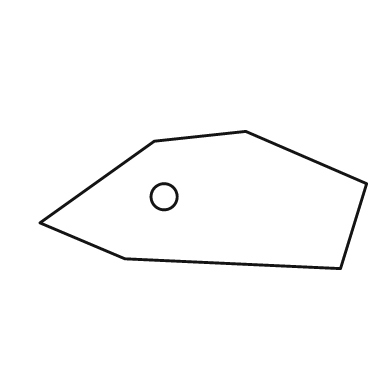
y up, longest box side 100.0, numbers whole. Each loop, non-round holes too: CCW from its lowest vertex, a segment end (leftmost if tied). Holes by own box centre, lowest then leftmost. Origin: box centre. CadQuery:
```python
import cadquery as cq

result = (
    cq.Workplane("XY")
    .moveTo(42.0, -21.0)
    .lineTo(50.0, 5.0)
    .lineTo(13.0, 21.0)
    .lineTo(-15.0, 18.0)
    .lineTo(-50.0, -7.0)
    .lineTo(-24.0, -18.0)
    .close()
    .moveTo(-12.0, 1.0)
    .circle(4.0)
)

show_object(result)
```